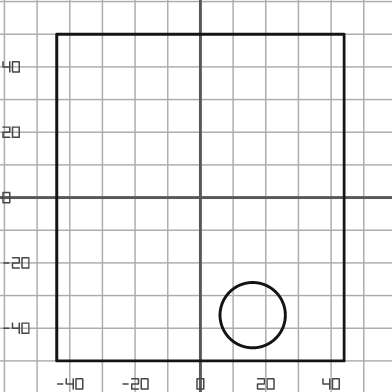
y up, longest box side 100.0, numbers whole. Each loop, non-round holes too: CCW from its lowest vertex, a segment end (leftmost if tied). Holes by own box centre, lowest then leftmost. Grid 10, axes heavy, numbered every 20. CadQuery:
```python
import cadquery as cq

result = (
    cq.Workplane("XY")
    .moveTo(-44.0, -50.0)
    .lineTo(44.0, -50.0)
    .lineTo(44.0, 50.0)
    .lineTo(-44.0, 50.0)
    .close()
    .moveTo(16.0, -36.0)
    .circle(10.0)
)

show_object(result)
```